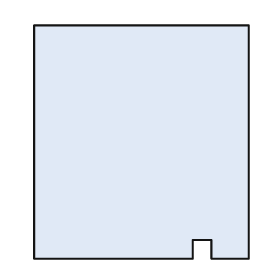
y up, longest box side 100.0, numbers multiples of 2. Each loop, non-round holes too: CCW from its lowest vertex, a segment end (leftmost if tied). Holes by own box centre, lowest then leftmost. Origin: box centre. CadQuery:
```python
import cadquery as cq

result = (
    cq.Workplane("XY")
    .moveTo(-46.0, -50.0)
    .lineTo(22.0, -50.0)
    .lineTo(22.0, -42.0)
    .lineTo(30.0, -42.0)
    .lineTo(30.0, -50.0)
    .lineTo(46.0, -50.0)
    .lineTo(46.0, 50.0)
    .lineTo(-46.0, 50.0)
    .close()
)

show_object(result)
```